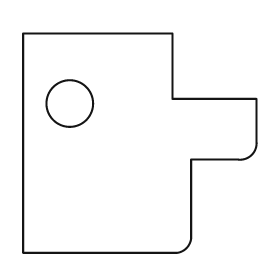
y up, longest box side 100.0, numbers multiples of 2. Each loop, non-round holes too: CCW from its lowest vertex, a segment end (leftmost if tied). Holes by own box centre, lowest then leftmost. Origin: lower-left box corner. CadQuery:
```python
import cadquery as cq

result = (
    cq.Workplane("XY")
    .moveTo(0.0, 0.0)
    .lineTo(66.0, 0.0)
    .threePointArc((70.0, 2.0), (72.0, 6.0))
    .lineTo(72.0, 40.0)
    .lineTo(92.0, 40.0)
    .threePointArc((98.0, 42.0), (100.0, 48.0))
    .lineTo(100.0, 66.0)
    .lineTo(64.0, 66.0)
    .lineTo(64.0, 94.0)
    .lineTo(0.0, 94.0)
    .close()
    .moveTo(20.0, 64.0)
    .circle(10.0)
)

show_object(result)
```